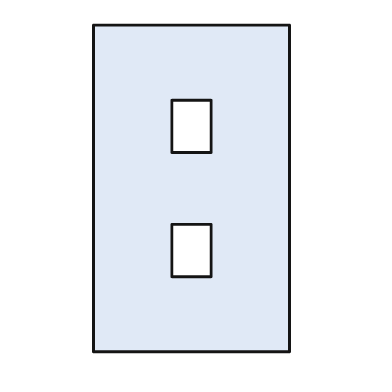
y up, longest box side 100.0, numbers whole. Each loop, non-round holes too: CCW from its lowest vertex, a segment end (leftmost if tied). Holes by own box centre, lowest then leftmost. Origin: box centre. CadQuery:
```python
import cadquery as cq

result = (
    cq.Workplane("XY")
    .moveTo(-30.0, -50.0)
    .lineTo(30.0, -50.0)
    .lineTo(30.0, 50.0)
    .lineTo(-30.0, 50.0)
    .close()
    .moveTo(-6.0, -27.0)
    .lineTo(6.0, -27.0)
    .lineTo(6.0, -11.0)
    .lineTo(-6.0, -11.0)
    .close()
    .moveTo(-6.0, 11.0)
    .lineTo(6.0, 11.0)
    .lineTo(6.0, 27.0)
    .lineTo(-6.0, 27.0)
    .close()
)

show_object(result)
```